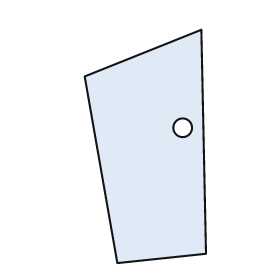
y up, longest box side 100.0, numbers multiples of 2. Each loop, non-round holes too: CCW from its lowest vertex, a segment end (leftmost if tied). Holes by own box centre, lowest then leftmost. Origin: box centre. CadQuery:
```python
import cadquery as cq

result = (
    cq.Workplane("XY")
    .moveTo(-12.0, -50.0)
    .lineTo(26.0, -46.0)
    .lineTo(24.0, 50.0)
    .lineTo(-26.0, 30.0)
    .close()
    .moveTo(16.0, 8.0)
    .circle(4.0)
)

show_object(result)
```